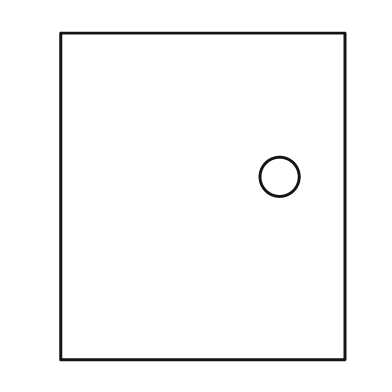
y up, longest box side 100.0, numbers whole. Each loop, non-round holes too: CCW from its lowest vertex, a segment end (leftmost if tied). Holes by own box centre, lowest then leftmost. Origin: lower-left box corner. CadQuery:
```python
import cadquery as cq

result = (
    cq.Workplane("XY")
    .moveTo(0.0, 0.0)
    .lineTo(87.0, 0.0)
    .lineTo(87.0, 100.0)
    .lineTo(0.0, 100.0)
    .close()
    .moveTo(67.0, 56.0)
    .circle(6.0)
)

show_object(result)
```